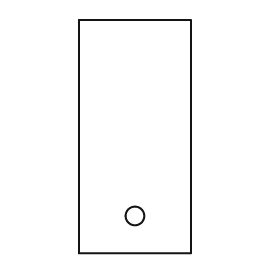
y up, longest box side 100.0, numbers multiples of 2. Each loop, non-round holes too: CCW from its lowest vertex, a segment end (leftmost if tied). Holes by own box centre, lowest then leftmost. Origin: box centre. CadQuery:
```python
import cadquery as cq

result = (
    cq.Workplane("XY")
    .moveTo(-24.0, -50.0)
    .lineTo(24.0, -50.0)
    .lineTo(24.0, 50.0)
    .lineTo(-24.0, 50.0)
    .close()
    .moveTo(0.0, -34.0)
    .circle(4.0)
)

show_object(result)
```